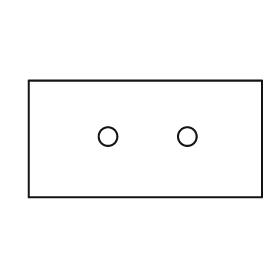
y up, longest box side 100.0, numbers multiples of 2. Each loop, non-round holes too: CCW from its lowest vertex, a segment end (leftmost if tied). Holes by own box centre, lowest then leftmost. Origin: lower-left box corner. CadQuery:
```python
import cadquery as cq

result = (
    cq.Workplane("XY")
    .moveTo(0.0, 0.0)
    .lineTo(100.0, 0.0)
    .lineTo(100.0, 50.0)
    .lineTo(0.0, 50.0)
    .close()
    .moveTo(34.0, 26.0)
    .circle(4.0)
    .moveTo(68.0, 26.0)
    .circle(4.0)
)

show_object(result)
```